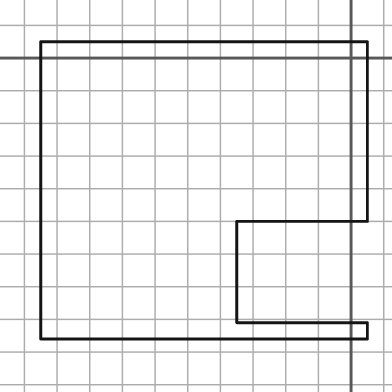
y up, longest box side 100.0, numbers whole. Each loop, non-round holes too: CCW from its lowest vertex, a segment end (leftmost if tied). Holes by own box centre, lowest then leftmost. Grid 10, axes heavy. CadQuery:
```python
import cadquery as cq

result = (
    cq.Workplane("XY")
    .moveTo(-95.0, -86.0)
    .lineTo(5.0, -86.0)
    .lineTo(5.0, -81.0)
    .lineTo(-35.0, -81.0)
    .lineTo(-35.0, -50.0)
    .lineTo(5.0, -50.0)
    .lineTo(5.0, 5.0)
    .lineTo(-95.0, 5.0)
    .close()
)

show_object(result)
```